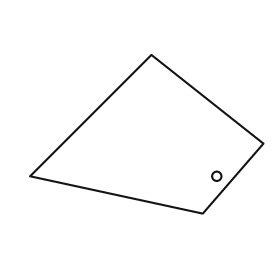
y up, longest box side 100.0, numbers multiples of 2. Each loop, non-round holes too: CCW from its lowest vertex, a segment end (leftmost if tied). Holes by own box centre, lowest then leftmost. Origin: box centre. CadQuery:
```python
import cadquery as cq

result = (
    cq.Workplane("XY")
    .moveTo(24.0, -34.0)
    .lineTo(50.0, -4.0)
    .lineTo(2.0, 34.0)
    .lineTo(-50.0, -18.0)
    .close()
    .moveTo(30.0, -18.0)
    .circle(2.0)
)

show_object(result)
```